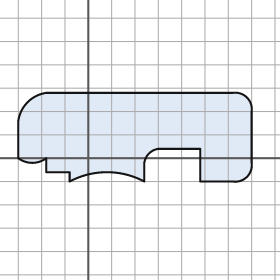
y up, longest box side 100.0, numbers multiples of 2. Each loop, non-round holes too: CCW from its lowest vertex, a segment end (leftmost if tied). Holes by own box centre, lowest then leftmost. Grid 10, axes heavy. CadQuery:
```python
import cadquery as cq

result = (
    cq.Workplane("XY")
    .moveTo(-8.0, -10.0)
    .threePointArc((8.0, -6.0), (24.0, -10.0))
    .lineTo(24.0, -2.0)
    .threePointArc((26.0, 2.0), (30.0, 4.0))
    .lineTo(48.0, 4.0)
    .lineTo(48.0, -10.0)
    .lineTo(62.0, -10.0)
    .threePointArc((68.0, -8.0), (70.0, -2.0))
    .lineTo(70.0, 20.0)
    .threePointArc((68.0, 26.0), (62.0, 28.0))
    .lineTo(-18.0, 28.0)
    .threePointArc((-26.0, 24.0), (-30.0, 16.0))
    .lineTo(-30.0, 0.0)
    .threePointArc((-24.0, -2.0), (-18.0, 0.0))
    .lineTo(-18.0, -6.0)
    .lineTo(-8.0, -6.0)
    .close()
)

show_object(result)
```